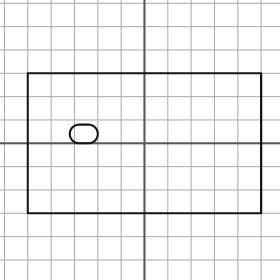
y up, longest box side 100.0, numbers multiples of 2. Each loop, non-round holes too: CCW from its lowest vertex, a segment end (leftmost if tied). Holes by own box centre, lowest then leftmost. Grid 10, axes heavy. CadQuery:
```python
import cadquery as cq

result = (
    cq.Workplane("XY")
    .moveTo(-50.0, -30.0)
    .lineTo(50.0, -30.0)
    .lineTo(50.0, 30.0)
    .lineTo(-50.0, 30.0)
    .close()
    .moveTo(-28.0, 0.0)
    .lineTo(-24.0, 0.0)
    .threePointArc((-20.0, 4.0), (-24.0, 8.0))
    .lineTo(-28.0, 8.0)
    .threePointArc((-32.0, 4.0), (-28.0, 0.0))
    .close()
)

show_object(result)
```